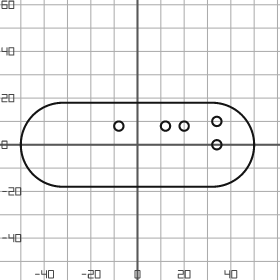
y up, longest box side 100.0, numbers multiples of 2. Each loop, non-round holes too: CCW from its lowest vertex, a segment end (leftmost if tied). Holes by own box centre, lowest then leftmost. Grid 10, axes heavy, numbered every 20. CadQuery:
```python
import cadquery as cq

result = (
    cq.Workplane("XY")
    .moveTo(-32.0, -18.0)
    .lineTo(32.0, -18.0)
    .threePointArc((50.0, 0.0), (32.0, 18.0))
    .lineTo(-32.0, 18.0)
    .threePointArc((-50.0, 0.0), (-32.0, -18.0))
    .close()
    .moveTo(34.0, 0.0)
    .circle(2.0)
    .moveTo(-8.0, 8.0)
    .circle(2.0)
    .moveTo(12.0, 8.0)
    .circle(2.0)
    .moveTo(20.0, 8.0)
    .circle(2.0)
    .moveTo(34.0, 10.0)
    .circle(2.0)
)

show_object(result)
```